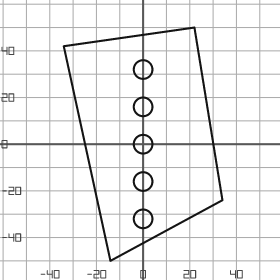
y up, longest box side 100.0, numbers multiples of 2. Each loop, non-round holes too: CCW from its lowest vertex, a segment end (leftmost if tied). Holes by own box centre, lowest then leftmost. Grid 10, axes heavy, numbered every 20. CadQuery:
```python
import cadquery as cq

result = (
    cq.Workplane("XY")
    .moveTo(-14.0, -50.0)
    .lineTo(34.0, -24.0)
    .lineTo(22.0, 50.0)
    .lineTo(-34.0, 42.0)
    .close()
    .moveTo(0.0, -32.0)
    .circle(4.0)
    .moveTo(0.0, -16.0)
    .circle(4.0)
    .moveTo(0.0, 0.0)
    .circle(4.0)
    .moveTo(0.0, 16.0)
    .circle(4.0)
    .moveTo(0.0, 32.0)
    .circle(4.0)
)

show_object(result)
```